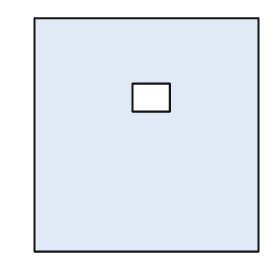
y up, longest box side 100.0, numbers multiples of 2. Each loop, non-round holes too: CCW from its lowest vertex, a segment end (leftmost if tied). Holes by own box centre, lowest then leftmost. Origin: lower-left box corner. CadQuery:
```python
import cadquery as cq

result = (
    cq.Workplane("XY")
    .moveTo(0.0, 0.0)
    .lineTo(96.0, 0.0)
    .lineTo(96.0, 100.0)
    .lineTo(0.0, 100.0)
    .close()
    .moveTo(42.0, 60.0)
    .lineTo(58.0, 60.0)
    .lineTo(58.0, 72.0)
    .lineTo(42.0, 72.0)
    .close()
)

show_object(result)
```